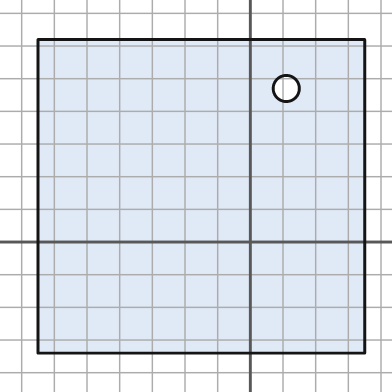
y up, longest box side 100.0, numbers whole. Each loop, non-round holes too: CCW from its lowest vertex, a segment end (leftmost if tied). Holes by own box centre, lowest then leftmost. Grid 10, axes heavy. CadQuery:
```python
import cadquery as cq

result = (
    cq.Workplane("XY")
    .moveTo(-65.0, -34.0)
    .lineTo(35.0, -34.0)
    .lineTo(35.0, 62.0)
    .lineTo(-65.0, 62.0)
    .close()
    .moveTo(11.0, 47.0)
    .circle(4.0)
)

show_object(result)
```